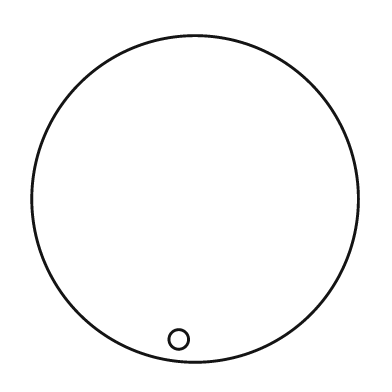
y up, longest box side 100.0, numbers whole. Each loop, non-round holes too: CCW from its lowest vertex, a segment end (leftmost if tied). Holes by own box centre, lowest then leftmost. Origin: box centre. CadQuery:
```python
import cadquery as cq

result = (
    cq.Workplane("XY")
    .moveTo(0.0, 0.0)
    .circle(50.0)
    .moveTo(-5.0, -43.0)
    .circle(3.0)
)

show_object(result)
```